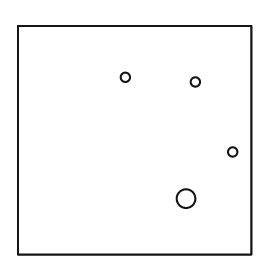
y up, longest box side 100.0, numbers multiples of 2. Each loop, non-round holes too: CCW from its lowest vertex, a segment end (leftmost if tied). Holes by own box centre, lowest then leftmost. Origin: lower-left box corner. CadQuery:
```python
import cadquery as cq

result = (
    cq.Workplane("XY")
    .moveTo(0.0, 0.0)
    .lineTo(100.0, 0.0)
    .lineTo(100.0, 98.0)
    .lineTo(0.0, 98.0)
    .close()
    .moveTo(72.0, 24.0)
    .circle(4.0)
    .moveTo(92.0, 44.0)
    .circle(2.0)
    .moveTo(76.0, 74.0)
    .circle(2.0)
    .moveTo(46.0, 76.0)
    .circle(2.0)
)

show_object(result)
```